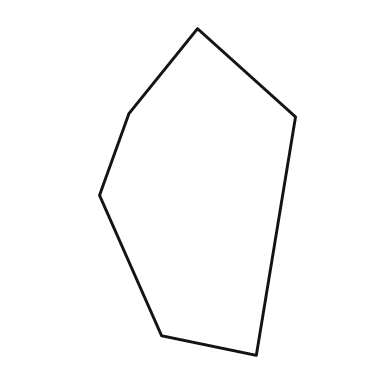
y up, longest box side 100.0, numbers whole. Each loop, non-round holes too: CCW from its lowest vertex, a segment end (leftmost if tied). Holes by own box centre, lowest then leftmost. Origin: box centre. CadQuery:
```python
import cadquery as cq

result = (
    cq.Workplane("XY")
    .moveTo(18.0, -50.0)
    .lineTo(30.0, 23.0)
    .lineTo(0.0, 50.0)
    .lineTo(-21.0, 24.0)
    .lineTo(-30.0, -1.0)
    .lineTo(-11.0, -44.0)
    .close()
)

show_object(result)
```